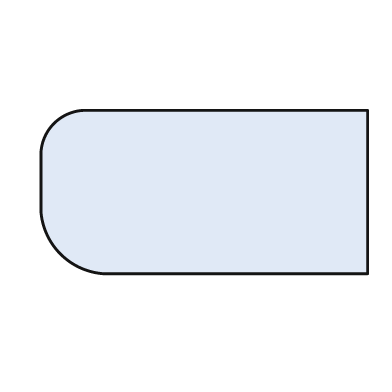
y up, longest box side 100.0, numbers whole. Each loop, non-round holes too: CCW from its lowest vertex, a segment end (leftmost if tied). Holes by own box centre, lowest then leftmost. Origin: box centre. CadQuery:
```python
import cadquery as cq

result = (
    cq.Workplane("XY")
    .moveTo(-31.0, -25.0)
    .lineTo(50.0, -25.0)
    .lineTo(50.0, 25.0)
    .lineTo(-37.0, 25.0)
    .threePointArc((-46.0, 21.0), (-50.0, 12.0))
    .lineTo(-50.0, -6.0)
    .threePointArc((-44.0, -19.0), (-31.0, -25.0))
    .close()
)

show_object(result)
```